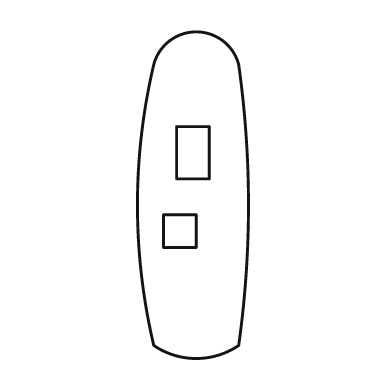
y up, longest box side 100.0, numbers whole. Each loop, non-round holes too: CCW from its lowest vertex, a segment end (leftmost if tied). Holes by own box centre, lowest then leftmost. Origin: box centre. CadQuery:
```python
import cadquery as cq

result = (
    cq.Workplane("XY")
    .moveTo(-12.0, -46.0)
    .threePointArc((1.0, -50.0), (14.0, -46.0))
    .threePointArc((17.0, -3.0), (14.0, 40.0))
    .threePointArc((1.0, 50.0), (-12.0, 40.0))
    .threePointArc((-17.0, -3.0), (-12.0, -46.0))
    .close()
    .moveTo(-9.0, -16.0)
    .lineTo(1.0, -16.0)
    .lineTo(1.0, -6.0)
    .lineTo(-9.0, -6.0)
    .close()
    .moveTo(-5.0, 5.0)
    .lineTo(5.0, 5.0)
    .lineTo(5.0, 21.0)
    .lineTo(-5.0, 21.0)
    .close()
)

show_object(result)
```